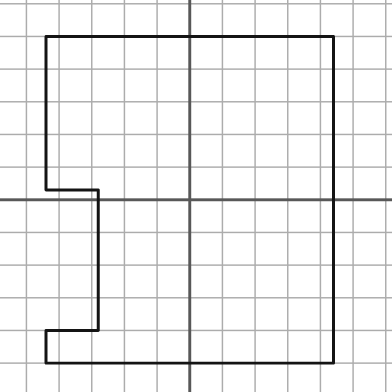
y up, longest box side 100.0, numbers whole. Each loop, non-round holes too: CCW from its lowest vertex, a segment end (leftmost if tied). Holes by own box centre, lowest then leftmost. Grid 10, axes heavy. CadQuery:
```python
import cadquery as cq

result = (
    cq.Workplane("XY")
    .moveTo(-44.0, -50.0)
    .lineTo(44.0, -50.0)
    .lineTo(44.0, 50.0)
    .lineTo(-44.0, 50.0)
    .lineTo(-44.0, 3.0)
    .lineTo(-28.0, 3.0)
    .lineTo(-28.0, -40.0)
    .lineTo(-44.0, -40.0)
    .close()
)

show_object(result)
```